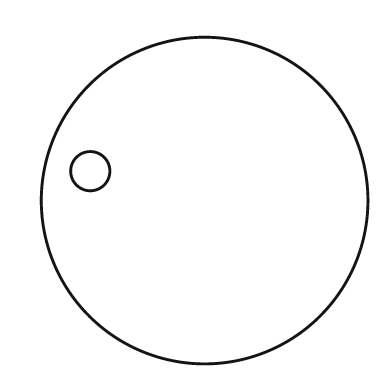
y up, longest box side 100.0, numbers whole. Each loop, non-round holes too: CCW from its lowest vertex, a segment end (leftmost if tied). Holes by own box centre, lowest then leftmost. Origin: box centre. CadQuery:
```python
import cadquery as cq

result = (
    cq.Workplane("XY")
    .moveTo(0.0, 0.0)
    .circle(50.0)
    .moveTo(-35.0, 9.0)
    .circle(6.0)
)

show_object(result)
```